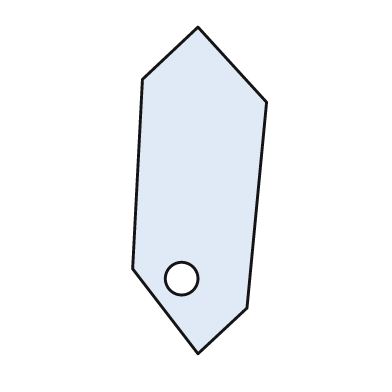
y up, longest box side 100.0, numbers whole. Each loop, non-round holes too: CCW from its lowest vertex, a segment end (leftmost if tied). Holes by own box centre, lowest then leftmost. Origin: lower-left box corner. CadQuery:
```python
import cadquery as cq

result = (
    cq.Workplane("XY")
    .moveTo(20.0, 0.0)
    .lineTo(35.0, 14.0)
    .lineTo(41.0, 77.0)
    .lineTo(20.0, 100.0)
    .lineTo(3.0, 84.0)
    .lineTo(0.0, 26.0)
    .close()
    .moveTo(15.0, 23.0)
    .circle(5.0)
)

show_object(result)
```